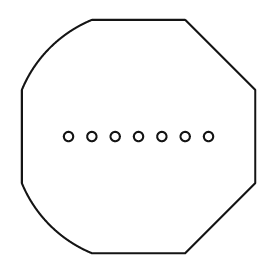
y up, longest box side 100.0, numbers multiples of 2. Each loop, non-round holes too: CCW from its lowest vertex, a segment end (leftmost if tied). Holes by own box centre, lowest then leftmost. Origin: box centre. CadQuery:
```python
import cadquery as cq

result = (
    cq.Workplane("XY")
    .moveTo(-20.0, -50.0)
    .lineTo(20.0, -50.0)
    .lineTo(50.0, -20.0)
    .lineTo(50.0, 20.0)
    .lineTo(20.0, 50.0)
    .lineTo(-20.0, 50.0)
    .threePointArc((-38.0, 38.0), (-50.0, 20.0))
    .lineTo(-50.0, -20.0)
    .threePointArc((-38.0, -38.0), (-20.0, -50.0))
    .close()
    .moveTo(-30.0, 0.0)
    .circle(2.0)
    .moveTo(-20.0, 0.0)
    .circle(2.0)
    .moveTo(-10.0, 0.0)
    .circle(2.0)
    .moveTo(0.0, 0.0)
    .circle(2.0)
    .moveTo(10.0, 0.0)
    .circle(2.0)
    .moveTo(20.0, 0.0)
    .circle(2.0)
    .moveTo(30.0, 0.0)
    .circle(2.0)
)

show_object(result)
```